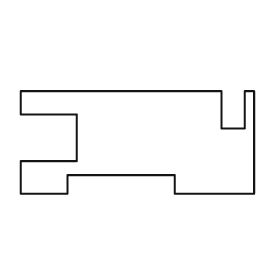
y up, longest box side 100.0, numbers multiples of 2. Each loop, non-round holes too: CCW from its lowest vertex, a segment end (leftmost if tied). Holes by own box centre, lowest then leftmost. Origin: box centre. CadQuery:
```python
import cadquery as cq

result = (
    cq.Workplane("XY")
    .moveTo(-50.0, -22.0)
    .lineTo(-30.0, -22.0)
    .lineTo(-30.0, -14.0)
    .lineTo(16.0, -14.0)
    .lineTo(16.0, -22.0)
    .lineTo(50.0, -22.0)
    .lineTo(50.0, 22.0)
    .lineTo(46.0, 22.0)
    .lineTo(46.0, 6.0)
    .lineTo(36.0, 6.0)
    .lineTo(36.0, 22.0)
    .lineTo(-50.0, 22.0)
    .lineTo(-50.0, 12.0)
    .lineTo(-26.0, 12.0)
    .lineTo(-26.0, -8.0)
    .lineTo(-50.0, -8.0)
    .close()
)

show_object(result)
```